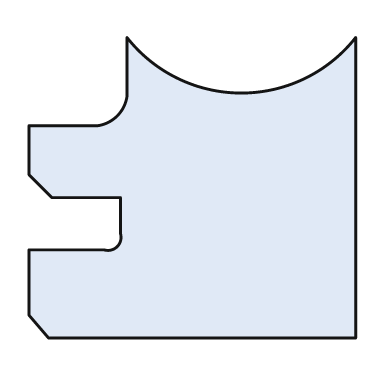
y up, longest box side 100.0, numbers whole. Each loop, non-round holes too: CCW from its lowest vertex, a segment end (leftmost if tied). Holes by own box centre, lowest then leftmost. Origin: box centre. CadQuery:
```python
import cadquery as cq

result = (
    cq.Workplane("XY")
    .moveTo(-44.0, -46.0)
    .lineTo(50.0, -46.0)
    .lineTo(50.0, 46.0)
    .threePointArc((15.0, 29.0), (-20.0, 46.0))
    .lineTo(-20.0, 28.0)
    .threePointArc((-23.0, 22.0), (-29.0, 19.0))
    .lineTo(-50.0, 19.0)
    .lineTo(-50.0, 4.0)
    .lineTo(-43.0, -3.0)
    .lineTo(-22.0, -3.0)
    .lineTo(-22.0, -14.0)
    .threePointArc((-23.0, -18.0), (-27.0, -19.0))
    .lineTo(-50.0, -19.0)
    .lineTo(-50.0, -39.0)
    .close()
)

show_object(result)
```